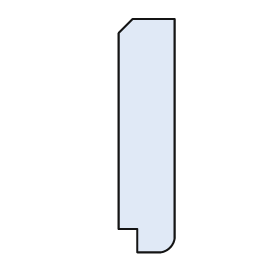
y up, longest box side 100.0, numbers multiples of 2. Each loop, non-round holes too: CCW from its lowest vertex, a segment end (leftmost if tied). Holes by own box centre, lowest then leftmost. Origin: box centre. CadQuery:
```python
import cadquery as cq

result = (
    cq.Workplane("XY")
    .moveTo(-4.0, -50.0)
    .lineTo(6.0, -50.0)
    .threePointArc((10.0, -48.0), (12.0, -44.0))
    .lineTo(12.0, 50.0)
    .lineTo(-6.0, 50.0)
    .lineTo(-12.0, 44.0)
    .lineTo(-12.0, -40.0)
    .lineTo(-4.0, -40.0)
    .close()
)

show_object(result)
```